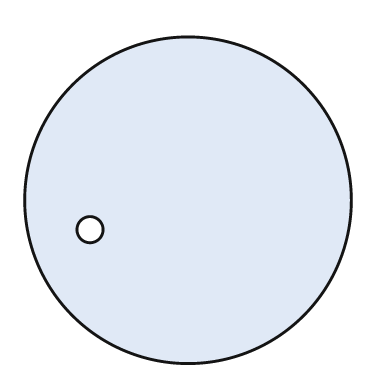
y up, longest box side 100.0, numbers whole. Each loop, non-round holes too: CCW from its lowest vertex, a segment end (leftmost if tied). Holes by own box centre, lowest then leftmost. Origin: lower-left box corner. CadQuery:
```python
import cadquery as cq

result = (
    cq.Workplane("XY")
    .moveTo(50.0, 50.0)
    .circle(50.0)
    .moveTo(20.0, 41.0)
    .circle(4.0)
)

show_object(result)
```